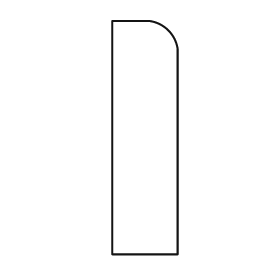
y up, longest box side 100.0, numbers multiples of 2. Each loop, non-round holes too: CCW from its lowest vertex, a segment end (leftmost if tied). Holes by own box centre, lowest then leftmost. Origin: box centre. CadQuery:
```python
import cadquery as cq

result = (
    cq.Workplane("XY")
    .moveTo(-14.0, -50.0)
    .lineTo(14.0, -50.0)
    .lineTo(14.0, 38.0)
    .threePointArc((10.0, 46.0), (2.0, 50.0))
    .lineTo(-14.0, 50.0)
    .close()
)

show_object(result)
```